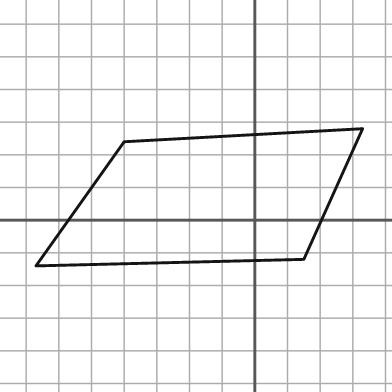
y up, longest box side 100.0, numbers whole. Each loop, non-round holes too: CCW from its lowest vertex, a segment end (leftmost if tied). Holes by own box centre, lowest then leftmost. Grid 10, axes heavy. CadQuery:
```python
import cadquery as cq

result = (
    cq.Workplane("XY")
    .moveTo(-67.0, -14.0)
    .lineTo(15.0, -12.0)
    .lineTo(33.0, 28.0)
    .lineTo(-40.0, 24.0)
    .close()
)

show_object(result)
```